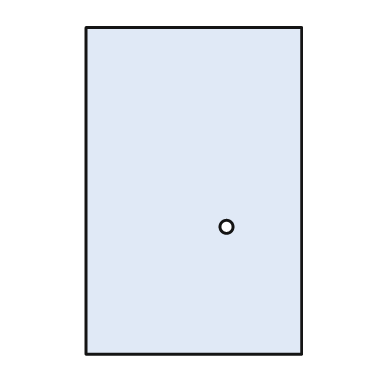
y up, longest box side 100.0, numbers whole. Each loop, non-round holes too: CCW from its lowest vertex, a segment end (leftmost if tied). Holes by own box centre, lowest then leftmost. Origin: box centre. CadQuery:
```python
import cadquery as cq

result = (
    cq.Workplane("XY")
    .moveTo(-33.0, -50.0)
    .lineTo(33.0, -50.0)
    .lineTo(33.0, 50.0)
    .lineTo(-33.0, 50.0)
    .close()
    .moveTo(10.0, -11.0)
    .circle(2.0)
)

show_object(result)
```